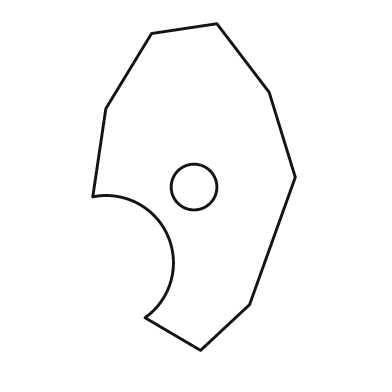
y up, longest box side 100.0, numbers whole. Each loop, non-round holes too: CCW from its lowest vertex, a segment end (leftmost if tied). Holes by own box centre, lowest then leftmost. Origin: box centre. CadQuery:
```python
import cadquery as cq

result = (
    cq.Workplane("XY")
    .moveTo(2.0, -50.0)
    .lineTo(17.0, -36.0)
    .lineTo(31.0, 3.0)
    .lineTo(23.0, 29.0)
    .lineTo(7.0, 50.0)
    .lineTo(-13.0, 47.0)
    .lineTo(-27.0, 24.0)
    .lineTo(-31.0, -3.0)
    .threePointArc((-8.0, -15.0), (-15.0, -40.0))
    .close()
    .moveTo(0.0, 0.0)
    .circle(7.0)
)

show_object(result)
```